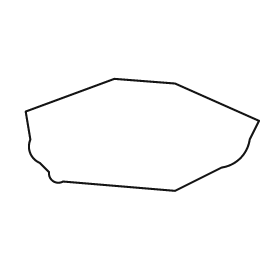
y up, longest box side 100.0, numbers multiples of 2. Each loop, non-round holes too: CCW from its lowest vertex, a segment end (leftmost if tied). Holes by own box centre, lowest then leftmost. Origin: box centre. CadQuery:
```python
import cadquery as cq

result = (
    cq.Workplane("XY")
    .moveTo(14.0, -24.0)
    .lineTo(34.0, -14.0)
    .threePointArc((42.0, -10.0), (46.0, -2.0))
    .lineTo(50.0, 6.0)
    .lineTo(14.0, 22.0)
    .lineTo(-12.0, 24.0)
    .lineTo(-50.0, 10.0)
    .lineTo(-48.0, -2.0)
    .threePointArc((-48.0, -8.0), (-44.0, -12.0))
    .lineTo(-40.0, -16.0)
    .threePointArc((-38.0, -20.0), (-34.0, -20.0))
    .close()
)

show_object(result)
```